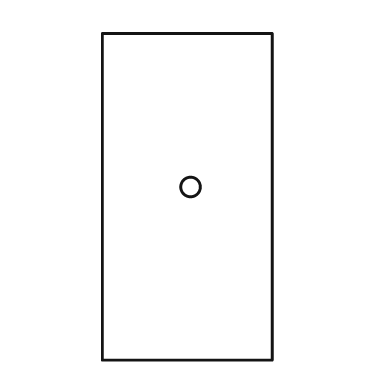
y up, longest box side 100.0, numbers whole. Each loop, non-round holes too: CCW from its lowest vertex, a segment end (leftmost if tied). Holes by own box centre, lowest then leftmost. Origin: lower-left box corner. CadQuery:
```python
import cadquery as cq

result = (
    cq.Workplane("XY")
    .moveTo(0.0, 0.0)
    .lineTo(52.0, 0.0)
    .lineTo(52.0, 100.0)
    .lineTo(0.0, 100.0)
    .close()
    .moveTo(27.0, 53.0)
    .circle(3.0)
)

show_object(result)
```